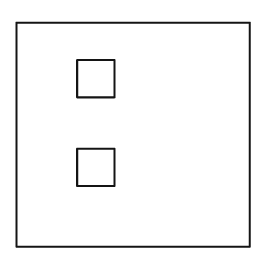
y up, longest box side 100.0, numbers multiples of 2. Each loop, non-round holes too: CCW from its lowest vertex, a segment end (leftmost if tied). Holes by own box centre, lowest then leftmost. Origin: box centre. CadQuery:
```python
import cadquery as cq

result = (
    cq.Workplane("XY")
    .moveTo(-50.0, -48.0)
    .lineTo(50.0, -48.0)
    .lineTo(50.0, 48.0)
    .lineTo(-50.0, 48.0)
    .close()
    .moveTo(-24.0, -22.0)
    .lineTo(-8.0, -22.0)
    .lineTo(-8.0, -6.0)
    .lineTo(-24.0, -6.0)
    .close()
    .moveTo(-24.0, 16.0)
    .lineTo(-8.0, 16.0)
    .lineTo(-8.0, 32.0)
    .lineTo(-24.0, 32.0)
    .close()
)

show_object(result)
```